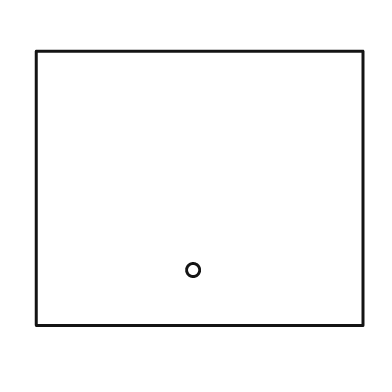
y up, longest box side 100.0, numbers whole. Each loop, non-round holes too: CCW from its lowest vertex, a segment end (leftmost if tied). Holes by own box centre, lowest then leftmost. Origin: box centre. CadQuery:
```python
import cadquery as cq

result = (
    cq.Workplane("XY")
    .moveTo(-50.0, -42.0)
    .lineTo(50.0, -42.0)
    .lineTo(50.0, 42.0)
    .lineTo(-50.0, 42.0)
    .close()
    .moveTo(-2.0, -25.0)
    .circle(2.0)
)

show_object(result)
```